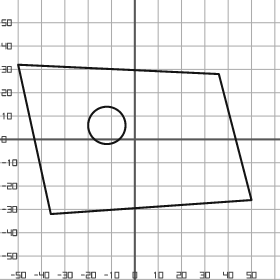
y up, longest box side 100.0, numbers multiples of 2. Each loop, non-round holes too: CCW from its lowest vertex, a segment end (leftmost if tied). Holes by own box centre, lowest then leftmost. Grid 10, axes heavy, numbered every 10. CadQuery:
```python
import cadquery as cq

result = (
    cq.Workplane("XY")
    .moveTo(-36.0, -32.0)
    .lineTo(50.0, -26.0)
    .lineTo(36.0, 28.0)
    .lineTo(-50.0, 32.0)
    .close()
    .moveTo(-12.0, 6.0)
    .circle(8.0)
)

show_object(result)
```